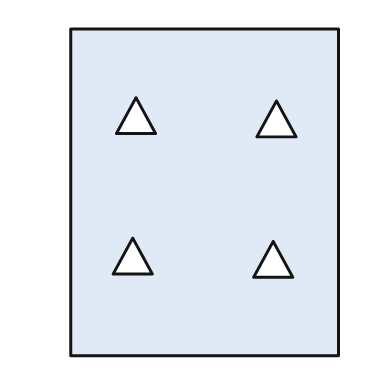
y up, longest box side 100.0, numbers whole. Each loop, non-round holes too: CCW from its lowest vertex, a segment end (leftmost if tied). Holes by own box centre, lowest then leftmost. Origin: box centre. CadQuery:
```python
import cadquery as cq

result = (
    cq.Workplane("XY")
    .moveTo(-41.0, -50.0)
    .lineTo(41.0, -50.0)
    .lineTo(41.0, 50.0)
    .lineTo(-41.0, 50.0)
    .close()
    .moveTo(15.0, -26.0)
    .lineTo(27.0, -26.0)
    .lineTo(21.0, -15.0)
    .close()
    .moveTo(-28.0, -25.0)
    .lineTo(-16.0, -25.0)
    .lineTo(-22.0, -14.0)
    .close()
    .moveTo(16.0, 17.0)
    .lineTo(28.0, 17.0)
    .lineTo(22.0, 28.0)
    .close()
    .moveTo(-27.0, 18.0)
    .lineTo(-15.0, 18.0)
    .lineTo(-21.0, 29.0)
    .close()
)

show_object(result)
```